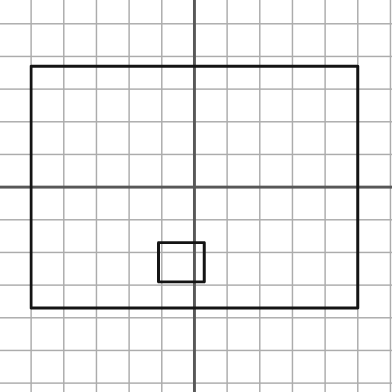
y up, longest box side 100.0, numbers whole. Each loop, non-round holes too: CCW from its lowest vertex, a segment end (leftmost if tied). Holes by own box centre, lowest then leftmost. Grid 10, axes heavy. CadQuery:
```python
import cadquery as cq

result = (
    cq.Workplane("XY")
    .moveTo(-50.0, -37.0)
    .lineTo(50.0, -37.0)
    .lineTo(50.0, 37.0)
    .lineTo(-50.0, 37.0)
    .close()
    .moveTo(-11.0, -29.0)
    .lineTo(3.0, -29.0)
    .lineTo(3.0, -17.0)
    .lineTo(-11.0, -17.0)
    .close()
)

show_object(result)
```